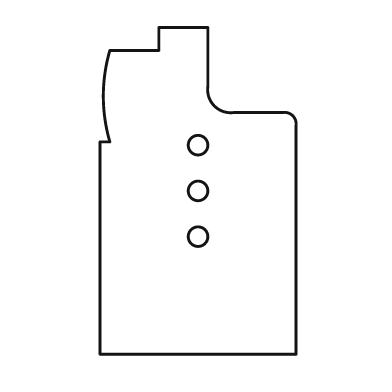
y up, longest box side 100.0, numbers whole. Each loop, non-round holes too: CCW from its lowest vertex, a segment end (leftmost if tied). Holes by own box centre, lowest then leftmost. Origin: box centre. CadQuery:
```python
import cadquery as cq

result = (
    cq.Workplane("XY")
    .moveTo(-30.0, -50.0)
    .lineTo(30.0, -50.0)
    .lineTo(30.0, 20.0)
    .threePointArc((29.0, 23.0), (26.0, 24.0))
    .lineTo(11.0, 24.0)
    .threePointArc((5.0, 26.0), (3.0, 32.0))
    .lineTo(3.0, 50.0)
    .lineTo(-12.0, 50.0)
    .lineTo(-12.0, 43.0)
    .lineTo(-27.0, 43.0)
    .threePointArc((-29.0, 29.0), (-27.0, 15.0))
    .lineTo(-30.0, 15.0)
    .close()
    .moveTo(0.0, -14.0)
    .circle(3.0)
    .moveTo(0.0, 0.0)
    .circle(3.0)
    .moveTo(0.0, 14.0)
    .circle(3.0)
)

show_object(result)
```